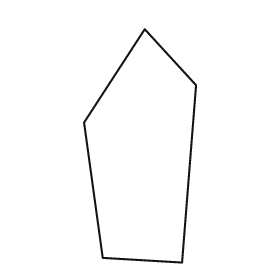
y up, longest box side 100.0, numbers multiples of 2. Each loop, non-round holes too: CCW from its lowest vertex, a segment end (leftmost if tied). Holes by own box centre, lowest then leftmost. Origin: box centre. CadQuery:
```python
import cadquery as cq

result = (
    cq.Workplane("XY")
    .moveTo(18.0, -50.0)
    .lineTo(24.0, 26.0)
    .lineTo(2.0, 50.0)
    .lineTo(-24.0, 10.0)
    .lineTo(-16.0, -48.0)
    .close()
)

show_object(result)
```